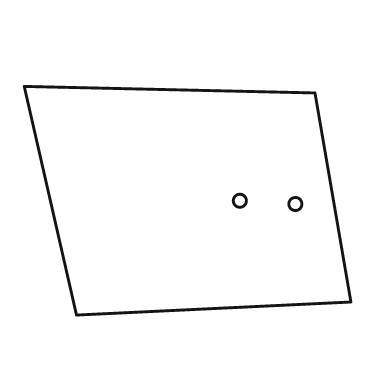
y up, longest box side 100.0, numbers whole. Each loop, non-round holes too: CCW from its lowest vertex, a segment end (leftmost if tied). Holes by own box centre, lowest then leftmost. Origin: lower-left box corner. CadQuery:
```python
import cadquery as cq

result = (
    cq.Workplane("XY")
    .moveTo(16.0, 0.0)
    .lineTo(100.0, 4.0)
    .lineTo(89.0, 68.0)
    .lineTo(0.0, 70.0)
    .close()
    .moveTo(83.0, 34.0)
    .circle(2.0)
    .moveTo(66.0, 35.0)
    .circle(2.0)
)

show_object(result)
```